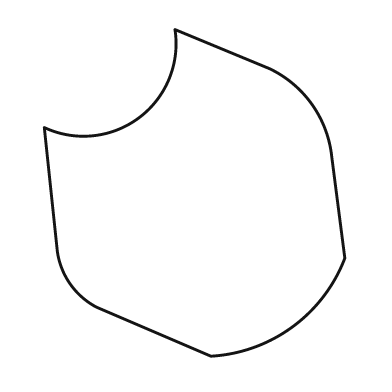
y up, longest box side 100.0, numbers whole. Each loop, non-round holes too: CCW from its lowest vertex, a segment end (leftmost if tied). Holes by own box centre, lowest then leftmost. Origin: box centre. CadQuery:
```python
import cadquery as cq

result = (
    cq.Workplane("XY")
    .moveTo(5.0, -50.0)
    .threePointArc((30.0, -41.0), (46.0, -20.0))
    .lineTo(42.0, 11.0)
    .threePointArc((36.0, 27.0), (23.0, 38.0))
    .lineTo(-6.0, 50.0)
    .threePointArc((-17.0, 23.0), (-46.0, 20.0))
    .lineTo(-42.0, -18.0)
    .threePointArc((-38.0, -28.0), (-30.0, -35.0))
    .close()
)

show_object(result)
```